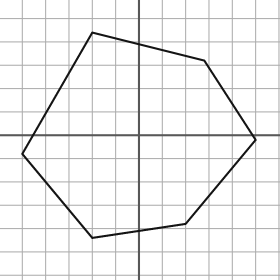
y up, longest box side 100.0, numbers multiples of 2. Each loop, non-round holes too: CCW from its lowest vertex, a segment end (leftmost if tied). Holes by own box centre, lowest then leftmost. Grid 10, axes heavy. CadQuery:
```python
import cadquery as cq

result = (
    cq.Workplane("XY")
    .moveTo(-20.0, -44.0)
    .lineTo(20.0, -38.0)
    .lineTo(50.0, -2.0)
    .lineTo(28.0, 32.0)
    .lineTo(-20.0, 44.0)
    .lineTo(-50.0, -8.0)
    .close()
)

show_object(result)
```